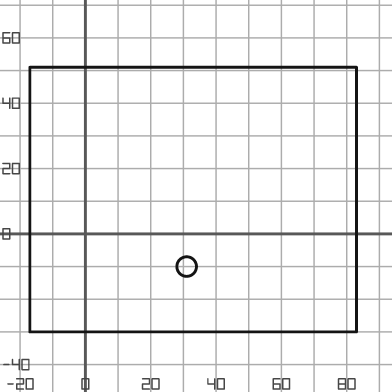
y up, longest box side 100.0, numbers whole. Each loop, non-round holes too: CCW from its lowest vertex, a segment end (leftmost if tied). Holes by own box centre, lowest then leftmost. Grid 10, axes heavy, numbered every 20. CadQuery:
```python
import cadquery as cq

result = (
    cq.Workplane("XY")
    .moveTo(-17.0, -30.0)
    .lineTo(83.0, -30.0)
    .lineTo(83.0, 51.0)
    .lineTo(-17.0, 51.0)
    .close()
    .moveTo(31.0, -10.0)
    .circle(3.0)
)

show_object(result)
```